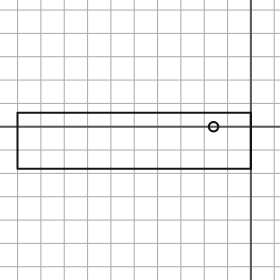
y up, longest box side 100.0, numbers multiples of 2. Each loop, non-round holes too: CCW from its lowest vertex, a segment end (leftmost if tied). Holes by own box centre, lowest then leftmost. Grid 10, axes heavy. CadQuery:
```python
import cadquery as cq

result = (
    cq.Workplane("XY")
    .moveTo(-100.0, -18.0)
    .lineTo(0.0, -18.0)
    .lineTo(0.0, 6.0)
    .lineTo(-100.0, 6.0)
    .close()
    .moveTo(-16.0, 0.0)
    .circle(2.0)
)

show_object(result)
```